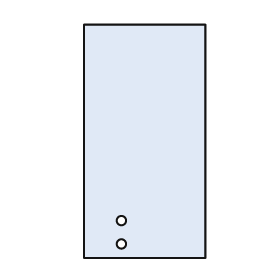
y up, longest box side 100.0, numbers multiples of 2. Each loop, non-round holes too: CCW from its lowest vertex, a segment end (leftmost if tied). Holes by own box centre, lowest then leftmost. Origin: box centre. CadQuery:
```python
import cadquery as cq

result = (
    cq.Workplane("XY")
    .moveTo(-26.0, -50.0)
    .lineTo(26.0, -50.0)
    .lineTo(26.0, 50.0)
    .lineTo(-26.0, 50.0)
    .close()
    .moveTo(-10.0, -44.0)
    .circle(2.0)
    .moveTo(-10.0, -34.0)
    .circle(2.0)
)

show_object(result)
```